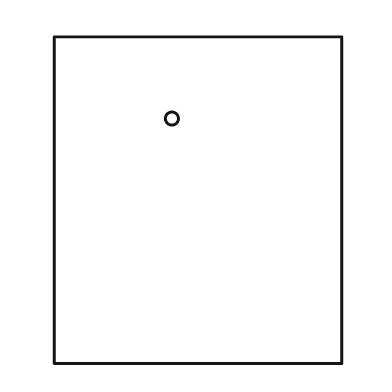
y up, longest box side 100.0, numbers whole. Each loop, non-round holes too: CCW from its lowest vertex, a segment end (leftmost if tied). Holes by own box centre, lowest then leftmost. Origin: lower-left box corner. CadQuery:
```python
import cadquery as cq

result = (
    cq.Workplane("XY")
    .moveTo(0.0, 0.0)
    .lineTo(88.0, 0.0)
    .lineTo(88.0, 100.0)
    .lineTo(0.0, 100.0)
    .close()
    .moveTo(36.0, 75.0)
    .circle(2.0)
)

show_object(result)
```